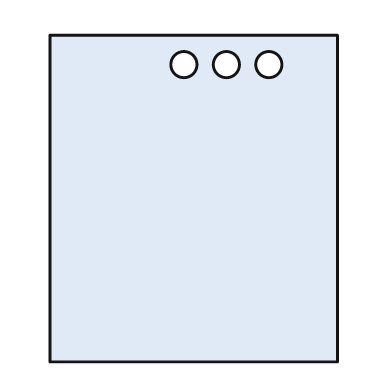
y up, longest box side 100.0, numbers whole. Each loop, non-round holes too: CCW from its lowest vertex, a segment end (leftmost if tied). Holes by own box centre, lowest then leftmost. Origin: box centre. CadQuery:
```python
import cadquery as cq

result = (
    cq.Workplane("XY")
    .moveTo(-44.0, -50.0)
    .lineTo(44.0, -50.0)
    .lineTo(44.0, 50.0)
    .lineTo(-44.0, 50.0)
    .close()
    .moveTo(-3.0, 41.0)
    .circle(4.0)
    .moveTo(10.0, 41.0)
    .circle(4.0)
    .moveTo(23.0, 41.0)
    .circle(4.0)
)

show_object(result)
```